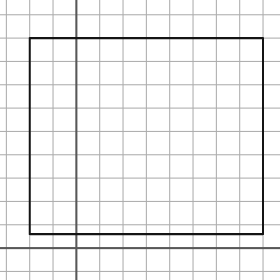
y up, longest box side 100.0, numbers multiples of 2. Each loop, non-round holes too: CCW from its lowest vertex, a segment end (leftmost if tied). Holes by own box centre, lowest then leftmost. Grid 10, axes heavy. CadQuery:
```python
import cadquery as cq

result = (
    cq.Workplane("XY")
    .moveTo(-20.0, 6.0)
    .lineTo(80.0, 6.0)
    .lineTo(80.0, 90.0)
    .lineTo(-20.0, 90.0)
    .close()
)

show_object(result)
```